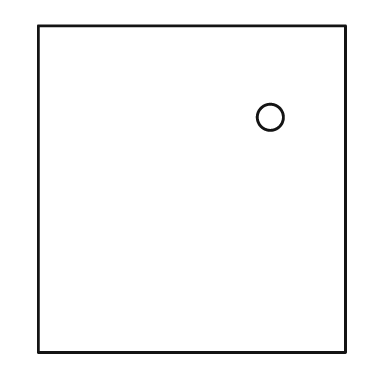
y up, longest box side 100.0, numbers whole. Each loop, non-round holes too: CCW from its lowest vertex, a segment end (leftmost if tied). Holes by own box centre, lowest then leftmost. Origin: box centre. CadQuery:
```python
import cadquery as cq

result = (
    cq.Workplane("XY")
    .moveTo(-47.0, -50.0)
    .lineTo(47.0, -50.0)
    .lineTo(47.0, 50.0)
    .lineTo(-47.0, 50.0)
    .close()
    .moveTo(24.0, 22.0)
    .circle(4.0)
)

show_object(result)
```